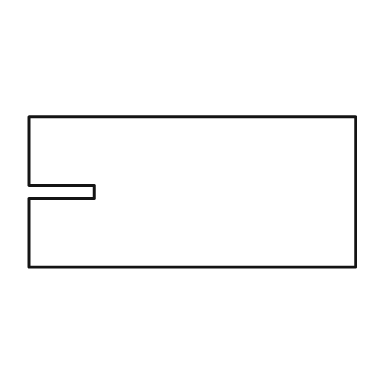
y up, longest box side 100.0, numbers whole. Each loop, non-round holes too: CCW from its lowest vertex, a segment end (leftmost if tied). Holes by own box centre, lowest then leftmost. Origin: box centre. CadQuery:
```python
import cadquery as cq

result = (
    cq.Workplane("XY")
    .moveTo(-50.0, -23.0)
    .lineTo(50.0, -23.0)
    .lineTo(50.0, 23.0)
    .lineTo(-50.0, 23.0)
    .lineTo(-50.0, 2.0)
    .lineTo(-30.0, 2.0)
    .lineTo(-30.0, -2.0)
    .lineTo(-50.0, -2.0)
    .close()
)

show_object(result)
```